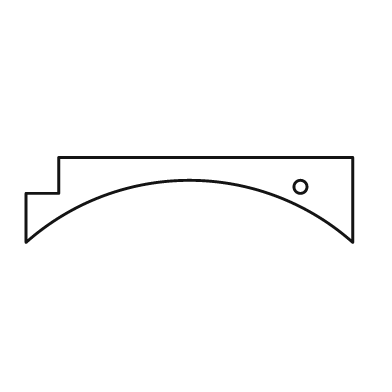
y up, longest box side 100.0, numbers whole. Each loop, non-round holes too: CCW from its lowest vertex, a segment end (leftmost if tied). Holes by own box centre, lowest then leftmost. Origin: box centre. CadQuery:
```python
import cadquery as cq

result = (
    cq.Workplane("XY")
    .moveTo(-50.0, -13.0)
    .threePointArc((0.0, 6.0), (50.0, -13.0))
    .lineTo(50.0, 13.0)
    .lineTo(-40.0, 13.0)
    .lineTo(-40.0, 2.0)
    .lineTo(-50.0, 2.0)
    .close()
    .moveTo(34.0, 4.0)
    .circle(2.0)
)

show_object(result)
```